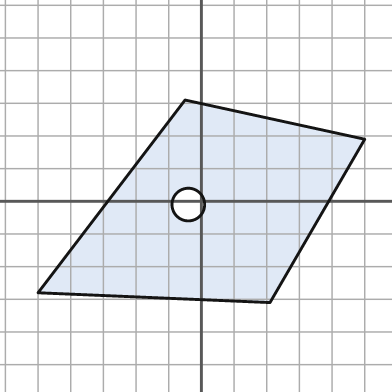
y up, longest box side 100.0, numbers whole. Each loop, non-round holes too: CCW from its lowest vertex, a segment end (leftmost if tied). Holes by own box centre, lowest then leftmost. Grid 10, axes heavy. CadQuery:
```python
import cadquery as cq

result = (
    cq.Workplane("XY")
    .moveTo(21.0, -31.0)
    .lineTo(50.0, 19.0)
    .lineTo(-5.0, 31.0)
    .lineTo(-50.0, -28.0)
    .close()
    .moveTo(-4.0, -1.0)
    .circle(5.0)
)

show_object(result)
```